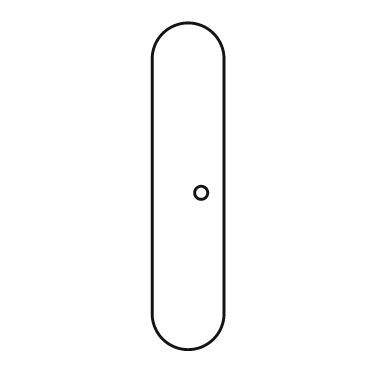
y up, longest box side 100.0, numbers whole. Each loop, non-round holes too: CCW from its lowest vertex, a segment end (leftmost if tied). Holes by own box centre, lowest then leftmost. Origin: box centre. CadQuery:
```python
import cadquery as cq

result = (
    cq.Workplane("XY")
    .moveTo(-11.0, -39.0)
    .threePointArc((0.0, -50.0), (11.0, -39.0))
    .lineTo(11.0, 39.0)
    .threePointArc((0.0, 50.0), (-11.0, 39.0))
    .close()
    .moveTo(4.0, -2.0)
    .circle(2.0)
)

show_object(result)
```